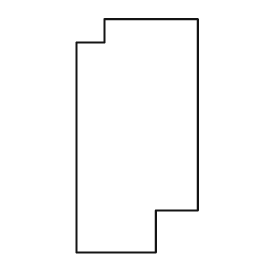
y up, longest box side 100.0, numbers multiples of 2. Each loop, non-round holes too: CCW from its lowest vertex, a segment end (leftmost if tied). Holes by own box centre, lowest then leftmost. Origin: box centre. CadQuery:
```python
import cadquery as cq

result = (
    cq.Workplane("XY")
    .moveTo(-26.0, -50.0)
    .lineTo(8.0, -50.0)
    .lineTo(8.0, -32.0)
    .lineTo(26.0, -32.0)
    .lineTo(26.0, 50.0)
    .lineTo(-14.0, 50.0)
    .lineTo(-14.0, 40.0)
    .lineTo(-26.0, 40.0)
    .close()
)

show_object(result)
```